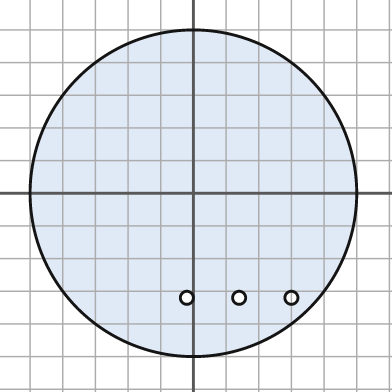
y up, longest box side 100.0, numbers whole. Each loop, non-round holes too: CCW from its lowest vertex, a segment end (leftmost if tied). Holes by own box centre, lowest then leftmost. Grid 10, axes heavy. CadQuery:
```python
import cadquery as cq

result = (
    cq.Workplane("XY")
    .moveTo(0.0, 0.0)
    .circle(50.0)
    .moveTo(-2.0, -32.0)
    .circle(2.0)
    .moveTo(14.0, -32.0)
    .circle(2.0)
    .moveTo(30.0, -32.0)
    .circle(2.0)
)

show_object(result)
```